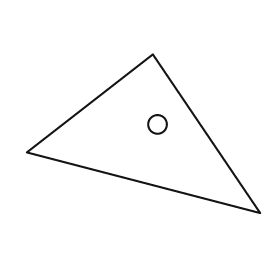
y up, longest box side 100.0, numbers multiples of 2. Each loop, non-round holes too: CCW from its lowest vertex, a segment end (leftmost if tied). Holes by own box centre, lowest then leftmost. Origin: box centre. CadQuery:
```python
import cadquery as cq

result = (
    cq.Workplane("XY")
    .moveTo(50.0, -34.0)
    .lineTo(4.0, 34.0)
    .lineTo(-50.0, -8.0)
    .close()
    .moveTo(6.0, 4.0)
    .circle(4.0)
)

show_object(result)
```